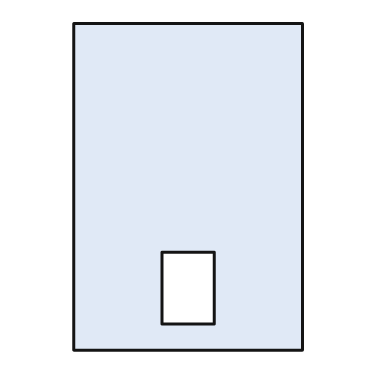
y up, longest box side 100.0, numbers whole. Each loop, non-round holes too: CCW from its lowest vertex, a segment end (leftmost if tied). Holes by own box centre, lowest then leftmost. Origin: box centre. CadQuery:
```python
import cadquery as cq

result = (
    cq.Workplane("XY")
    .moveTo(-35.0, -50.0)
    .lineTo(35.0, -50.0)
    .lineTo(35.0, 50.0)
    .lineTo(-35.0, 50.0)
    .close()
    .moveTo(-8.0, -42.0)
    .lineTo(8.0, -42.0)
    .lineTo(8.0, -20.0)
    .lineTo(-8.0, -20.0)
    .close()
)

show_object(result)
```